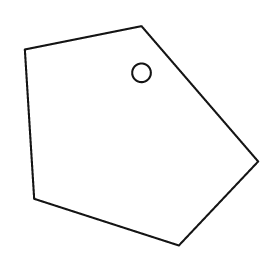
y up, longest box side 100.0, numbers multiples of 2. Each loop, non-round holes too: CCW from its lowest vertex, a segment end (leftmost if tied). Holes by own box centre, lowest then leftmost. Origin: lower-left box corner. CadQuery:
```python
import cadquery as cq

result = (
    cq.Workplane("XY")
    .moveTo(66.0, 0.0)
    .lineTo(100.0, 36.0)
    .lineTo(50.0, 94.0)
    .lineTo(0.0, 84.0)
    .lineTo(4.0, 20.0)
    .close()
    .moveTo(50.0, 74.0)
    .circle(4.0)
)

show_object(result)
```